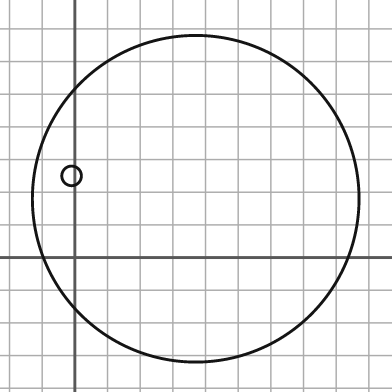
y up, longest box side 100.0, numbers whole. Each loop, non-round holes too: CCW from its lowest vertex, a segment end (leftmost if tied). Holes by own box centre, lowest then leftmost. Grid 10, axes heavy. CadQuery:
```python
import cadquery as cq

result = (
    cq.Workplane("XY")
    .moveTo(37.0, 18.0)
    .circle(50.0)
    .moveTo(-1.0, 25.0)
    .circle(3.0)
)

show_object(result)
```